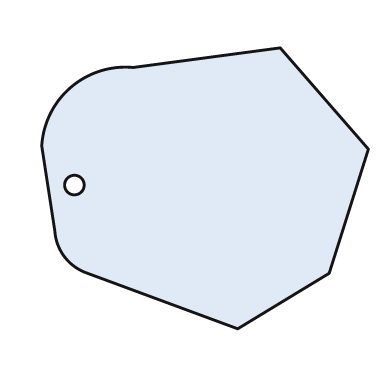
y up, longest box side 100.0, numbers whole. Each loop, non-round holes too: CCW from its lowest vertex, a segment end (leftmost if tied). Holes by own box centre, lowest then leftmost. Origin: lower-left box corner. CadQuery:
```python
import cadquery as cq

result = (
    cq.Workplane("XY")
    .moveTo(60.0, 0.0)
    .lineTo(88.0, 17.0)
    .lineTo(100.0, 55.0)
    .lineTo(73.0, 86.0)
    .lineTo(28.0, 80.0)
    .threePointArc((9.0, 74.0), (0.0, 56.0))
    .lineTo(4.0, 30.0)
    .threePointArc((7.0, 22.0), (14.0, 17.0))
    .close()
    .moveTo(10.0, 44.0)
    .circle(3.0)
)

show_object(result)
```